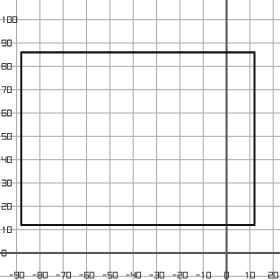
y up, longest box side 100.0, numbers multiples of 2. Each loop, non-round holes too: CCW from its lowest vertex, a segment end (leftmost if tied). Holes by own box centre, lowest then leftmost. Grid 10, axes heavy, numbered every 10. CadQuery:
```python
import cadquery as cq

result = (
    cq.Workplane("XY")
    .moveTo(-88.0, 12.0)
    .lineTo(12.0, 12.0)
    .lineTo(12.0, 86.0)
    .lineTo(-88.0, 86.0)
    .close()
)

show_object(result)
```